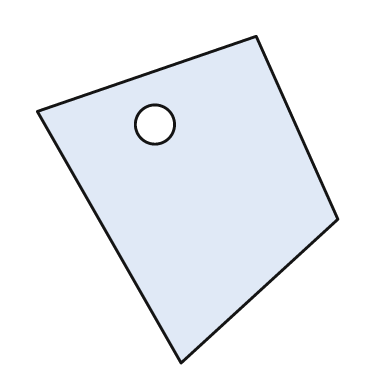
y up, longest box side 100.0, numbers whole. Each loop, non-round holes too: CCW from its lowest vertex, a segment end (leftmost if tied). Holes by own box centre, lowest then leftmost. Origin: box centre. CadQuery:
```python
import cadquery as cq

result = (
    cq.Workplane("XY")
    .moveTo(-2.0, -50.0)
    .lineTo(46.0, -6.0)
    .lineTo(21.0, 50.0)
    .lineTo(-46.0, 27.0)
    .close()
    .moveTo(-10.0, 23.0)
    .circle(6.0)
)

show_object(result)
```